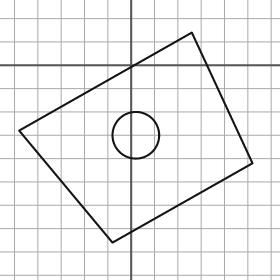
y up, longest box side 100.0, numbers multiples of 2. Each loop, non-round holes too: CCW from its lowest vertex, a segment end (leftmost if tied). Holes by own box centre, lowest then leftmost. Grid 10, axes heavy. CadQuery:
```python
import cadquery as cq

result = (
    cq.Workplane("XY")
    .moveTo(-8.0, -76.0)
    .lineTo(52.0, -42.0)
    .lineTo(26.0, 14.0)
    .lineTo(-48.0, -28.0)
    .close()
    .moveTo(2.0, -30.0)
    .circle(10.0)
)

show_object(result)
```